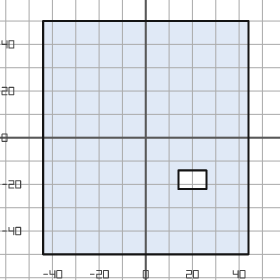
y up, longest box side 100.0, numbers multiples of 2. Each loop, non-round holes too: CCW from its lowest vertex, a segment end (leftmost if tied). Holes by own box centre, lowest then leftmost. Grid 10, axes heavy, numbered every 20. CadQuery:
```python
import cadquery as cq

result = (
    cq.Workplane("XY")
    .moveTo(-44.0, -50.0)
    .lineTo(44.0, -50.0)
    .lineTo(44.0, 50.0)
    .lineTo(-44.0, 50.0)
    .close()
    .moveTo(14.0, -22.0)
    .lineTo(26.0, -22.0)
    .lineTo(26.0, -14.0)
    .lineTo(14.0, -14.0)
    .close()
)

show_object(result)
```